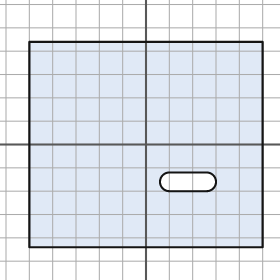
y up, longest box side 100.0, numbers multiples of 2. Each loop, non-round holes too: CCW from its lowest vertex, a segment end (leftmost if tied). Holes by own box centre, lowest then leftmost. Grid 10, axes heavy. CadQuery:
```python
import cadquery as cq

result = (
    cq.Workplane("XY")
    .moveTo(-50.0, -44.0)
    .lineTo(50.0, -44.0)
    .lineTo(50.0, 44.0)
    .lineTo(-50.0, 44.0)
    .close()
    .moveTo(10.0, -20.0)
    .lineTo(26.0, -20.0)
    .threePointArc((30.0, -16.0), (26.0, -12.0))
    .lineTo(10.0, -12.0)
    .threePointArc((6.0, -16.0), (10.0, -20.0))
    .close()
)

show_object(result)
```